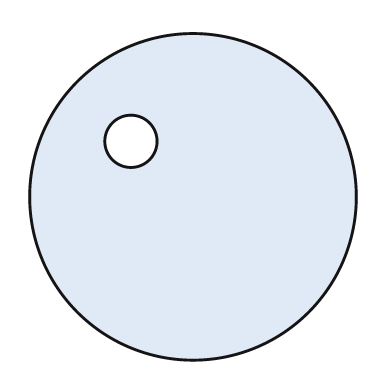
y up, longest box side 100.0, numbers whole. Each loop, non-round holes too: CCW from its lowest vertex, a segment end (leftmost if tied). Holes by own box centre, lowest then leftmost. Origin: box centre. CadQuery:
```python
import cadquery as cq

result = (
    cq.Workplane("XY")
    .moveTo(0.0, 0.0)
    .circle(50.0)
    .moveTo(-19.0, 17.0)
    .circle(8.0)
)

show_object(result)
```